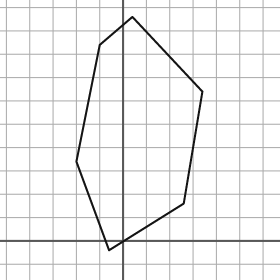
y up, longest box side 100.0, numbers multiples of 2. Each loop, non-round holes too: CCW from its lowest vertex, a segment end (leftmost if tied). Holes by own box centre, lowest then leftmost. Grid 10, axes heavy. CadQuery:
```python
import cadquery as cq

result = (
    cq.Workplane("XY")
    .moveTo(-6.0, -4.0)
    .lineTo(26.0, 16.0)
    .lineTo(34.0, 64.0)
    .lineTo(4.0, 96.0)
    .lineTo(-10.0, 84.0)
    .lineTo(-20.0, 34.0)
    .close()
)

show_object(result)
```